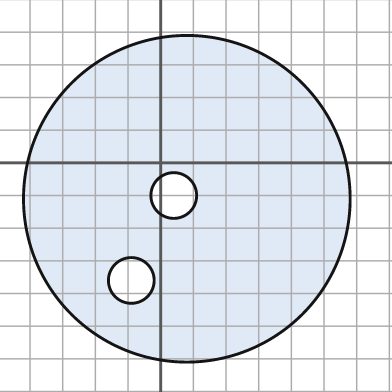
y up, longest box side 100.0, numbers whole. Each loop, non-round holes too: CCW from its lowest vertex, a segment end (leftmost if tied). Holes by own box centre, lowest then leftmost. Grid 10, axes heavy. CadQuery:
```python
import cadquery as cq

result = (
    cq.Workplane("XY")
    .moveTo(8.0, -11.0)
    .circle(50.0)
    .moveTo(-9.0, -36.0)
    .circle(7.0)
    .moveTo(4.0, -10.0)
    .circle(7.0)
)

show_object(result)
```